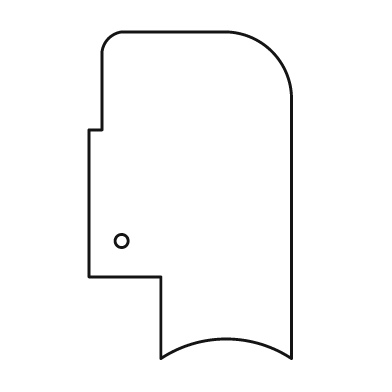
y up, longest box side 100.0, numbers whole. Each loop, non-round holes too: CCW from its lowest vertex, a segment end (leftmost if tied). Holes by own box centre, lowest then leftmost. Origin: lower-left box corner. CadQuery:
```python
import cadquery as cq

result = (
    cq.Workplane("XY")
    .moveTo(22.0, 0.0)
    .threePointArc((42.0, 6.0), (62.0, 0.0))
    .lineTo(62.0, 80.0)
    .threePointArc((56.0, 94.0), (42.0, 100.0))
    .lineTo(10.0, 100.0)
    .threePointArc((6.0, 98.0), (4.0, 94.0))
    .lineTo(4.0, 70.0)
    .lineTo(0.0, 70.0)
    .lineTo(0.0, 25.0)
    .lineTo(22.0, 25.0)
    .close()
    .moveTo(10.0, 36.0)
    .circle(2.0)
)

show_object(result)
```